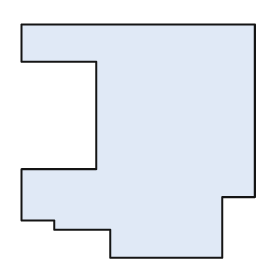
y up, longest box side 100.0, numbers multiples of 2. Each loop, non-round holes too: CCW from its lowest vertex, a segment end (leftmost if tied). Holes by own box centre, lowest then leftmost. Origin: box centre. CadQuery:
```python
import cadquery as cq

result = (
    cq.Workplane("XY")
    .moveTo(-12.0, -50.0)
    .lineTo(36.0, -50.0)
    .lineTo(36.0, -24.0)
    .lineTo(50.0, -24.0)
    .lineTo(50.0, 50.0)
    .lineTo(-50.0, 50.0)
    .lineTo(-50.0, 34.0)
    .lineTo(-18.0, 34.0)
    .lineTo(-18.0, -12.0)
    .lineTo(-50.0, -12.0)
    .lineTo(-50.0, -34.0)
    .lineTo(-36.0, -34.0)
    .lineTo(-36.0, -38.0)
    .lineTo(-12.0, -38.0)
    .close()
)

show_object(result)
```